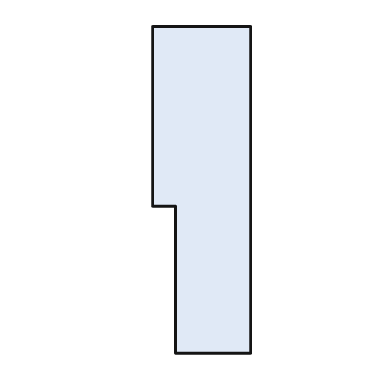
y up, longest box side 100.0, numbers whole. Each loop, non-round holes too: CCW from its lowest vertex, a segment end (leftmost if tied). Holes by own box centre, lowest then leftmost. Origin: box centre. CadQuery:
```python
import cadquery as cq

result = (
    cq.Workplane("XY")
    .moveTo(-8.0, -50.0)
    .lineTo(15.0, -50.0)
    .lineTo(15.0, 50.0)
    .lineTo(-15.0, 50.0)
    .lineTo(-15.0, -5.0)
    .lineTo(-8.0, -5.0)
    .close()
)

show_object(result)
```